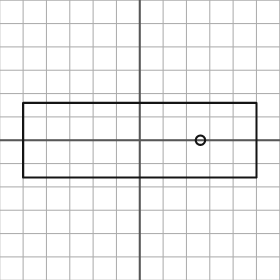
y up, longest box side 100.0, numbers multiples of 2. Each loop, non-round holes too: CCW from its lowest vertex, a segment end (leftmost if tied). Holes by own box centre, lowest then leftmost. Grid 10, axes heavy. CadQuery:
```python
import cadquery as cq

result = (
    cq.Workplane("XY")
    .moveTo(-50.0, -16.0)
    .lineTo(50.0, -16.0)
    .lineTo(50.0, 16.0)
    .lineTo(-50.0, 16.0)
    .close()
    .moveTo(26.0, 0.0)
    .circle(2.0)
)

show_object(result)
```